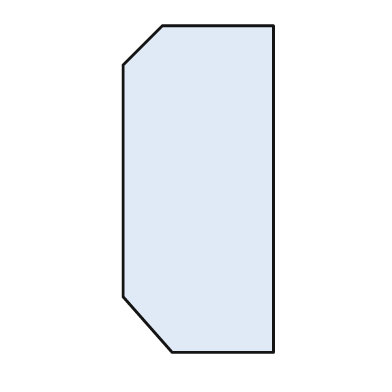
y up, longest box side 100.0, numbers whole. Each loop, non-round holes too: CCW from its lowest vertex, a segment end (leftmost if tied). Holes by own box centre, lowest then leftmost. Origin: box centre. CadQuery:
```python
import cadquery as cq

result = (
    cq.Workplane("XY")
    .moveTo(-8.0, -50.0)
    .lineTo(23.0, -50.0)
    .lineTo(23.0, 50.0)
    .lineTo(-11.0, 50.0)
    .lineTo(-23.0, 38.0)
    .lineTo(-23.0, -33.0)
    .close()
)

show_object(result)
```